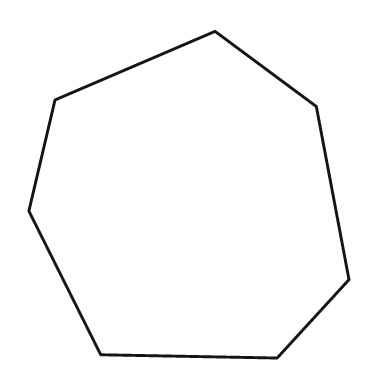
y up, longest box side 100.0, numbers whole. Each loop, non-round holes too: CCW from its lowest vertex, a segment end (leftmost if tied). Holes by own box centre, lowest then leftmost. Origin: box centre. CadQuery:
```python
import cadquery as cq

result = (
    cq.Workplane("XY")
    .moveTo(27.0, -50.0)
    .lineTo(49.0, -26.0)
    .lineTo(39.0, 27.0)
    .lineTo(8.0, 50.0)
    .lineTo(-41.0, 29.0)
    .lineTo(-49.0, -5.0)
    .lineTo(-27.0, -49.0)
    .close()
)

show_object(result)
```